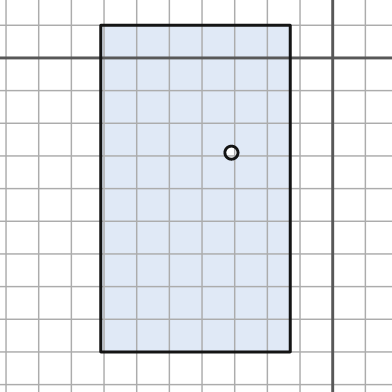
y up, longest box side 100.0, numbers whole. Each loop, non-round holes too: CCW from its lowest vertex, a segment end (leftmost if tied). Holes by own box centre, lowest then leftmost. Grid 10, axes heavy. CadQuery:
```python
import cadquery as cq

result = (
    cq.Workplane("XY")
    .moveTo(-71.0, -90.0)
    .lineTo(-13.0, -90.0)
    .lineTo(-13.0, 10.0)
    .lineTo(-71.0, 10.0)
    .close()
    .moveTo(-31.0, -29.0)
    .circle(2.0)
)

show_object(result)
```